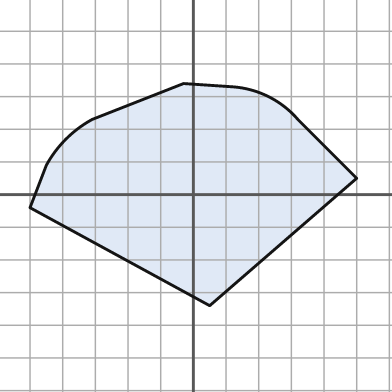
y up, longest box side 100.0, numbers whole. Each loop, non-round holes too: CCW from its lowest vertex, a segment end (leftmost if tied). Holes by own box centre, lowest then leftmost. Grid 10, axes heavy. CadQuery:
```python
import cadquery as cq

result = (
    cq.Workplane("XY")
    .moveTo(5.0, -34.0)
    .lineTo(50.0, 5.0)
    .lineTo(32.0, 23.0)
    .threePointArc((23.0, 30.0), (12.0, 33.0))
    .lineTo(-3.0, 34.0)
    .lineTo(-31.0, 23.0)
    .threePointArc((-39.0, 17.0), (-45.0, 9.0))
    .lineTo(-50.0, -4.0)
    .close()
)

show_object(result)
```